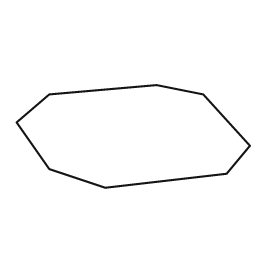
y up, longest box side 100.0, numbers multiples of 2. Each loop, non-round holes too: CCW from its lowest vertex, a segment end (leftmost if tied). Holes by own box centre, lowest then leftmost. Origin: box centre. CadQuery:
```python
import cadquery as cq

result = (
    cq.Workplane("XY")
    .moveTo(-12.0, -22.0)
    .lineTo(40.0, -16.0)
    .lineTo(50.0, -4.0)
    .lineTo(30.0, 18.0)
    .lineTo(10.0, 22.0)
    .lineTo(-36.0, 18.0)
    .lineTo(-50.0, 6.0)
    .lineTo(-36.0, -14.0)
    .close()
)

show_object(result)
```